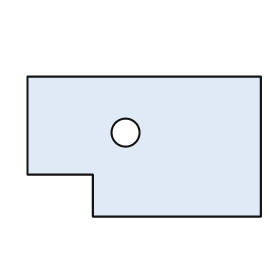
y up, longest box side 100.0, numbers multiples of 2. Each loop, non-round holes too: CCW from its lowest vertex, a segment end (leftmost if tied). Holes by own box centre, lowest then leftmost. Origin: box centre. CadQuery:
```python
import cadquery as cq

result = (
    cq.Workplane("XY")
    .moveTo(-22.0, -30.0)
    .lineTo(50.0, -30.0)
    .lineTo(50.0, 30.0)
    .lineTo(-50.0, 30.0)
    .lineTo(-50.0, -12.0)
    .lineTo(-22.0, -12.0)
    .close()
    .moveTo(-8.0, 6.0)
    .circle(6.0)
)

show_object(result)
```